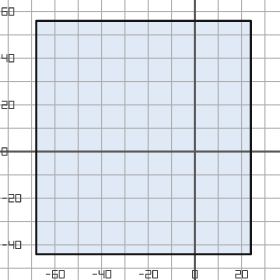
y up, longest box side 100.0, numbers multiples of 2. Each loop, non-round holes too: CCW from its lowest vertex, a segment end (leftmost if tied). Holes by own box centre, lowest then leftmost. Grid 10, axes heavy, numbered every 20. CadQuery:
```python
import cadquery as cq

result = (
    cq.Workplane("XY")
    .moveTo(-68.0, -44.0)
    .lineTo(24.0, -44.0)
    .lineTo(24.0, 56.0)
    .lineTo(-68.0, 56.0)
    .close()
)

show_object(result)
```